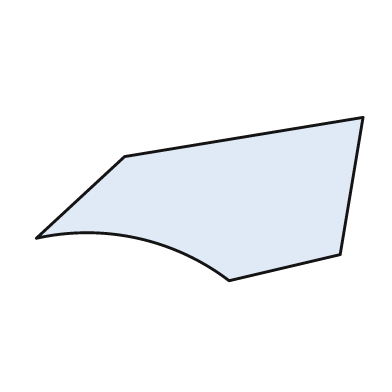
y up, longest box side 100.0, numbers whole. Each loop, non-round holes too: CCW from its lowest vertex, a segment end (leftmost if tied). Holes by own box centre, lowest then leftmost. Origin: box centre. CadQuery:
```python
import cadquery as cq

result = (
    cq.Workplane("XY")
    .moveTo(9.0, -25.0)
    .lineTo(43.0, -17.0)
    .lineTo(50.0, 25.0)
    .lineTo(-23.0, 13.0)
    .lineTo(-50.0, -12.0)
    .threePointArc((-19.0, -12.0), (9.0, -25.0))
    .close()
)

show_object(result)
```